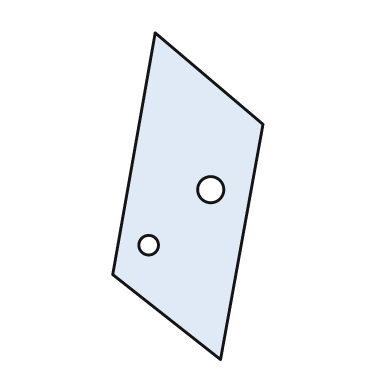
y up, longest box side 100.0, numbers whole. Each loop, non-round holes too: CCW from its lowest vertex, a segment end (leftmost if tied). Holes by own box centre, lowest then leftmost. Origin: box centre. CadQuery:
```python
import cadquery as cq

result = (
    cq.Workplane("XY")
    .moveTo(10.0, -50.0)
    .lineTo(23.0, 22.0)
    .lineTo(-10.0, 50.0)
    .lineTo(-23.0, -24.0)
    .close()
    .moveTo(-12.0, -15.0)
    .circle(3.0)
    .moveTo(7.0, 2.0)
    .circle(4.0)
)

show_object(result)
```